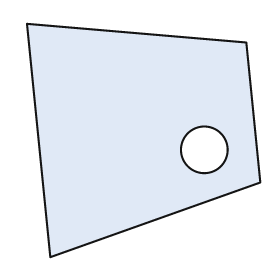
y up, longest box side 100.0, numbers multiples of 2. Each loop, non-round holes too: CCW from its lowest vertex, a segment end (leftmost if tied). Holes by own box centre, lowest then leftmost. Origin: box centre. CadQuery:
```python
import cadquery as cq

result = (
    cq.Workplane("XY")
    .moveTo(-40.0, -50.0)
    .lineTo(50.0, -18.0)
    .lineTo(44.0, 42.0)
    .lineTo(-50.0, 50.0)
    .close()
    .moveTo(26.0, -4.0)
    .circle(10.0)
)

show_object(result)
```